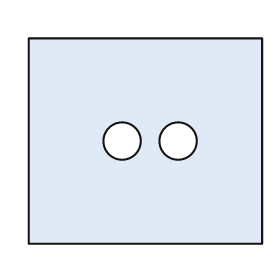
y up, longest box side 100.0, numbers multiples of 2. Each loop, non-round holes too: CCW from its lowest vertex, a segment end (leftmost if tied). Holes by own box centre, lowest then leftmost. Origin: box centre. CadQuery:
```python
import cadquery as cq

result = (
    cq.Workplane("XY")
    .moveTo(-50.0, -44.0)
    .lineTo(50.0, -44.0)
    .lineTo(50.0, 44.0)
    .lineTo(-50.0, 44.0)
    .close()
    .moveTo(-10.0, 0.0)
    .circle(8.0)
    .moveTo(14.0, 0.0)
    .circle(8.0)
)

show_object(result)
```